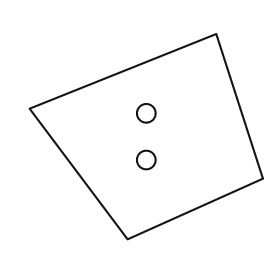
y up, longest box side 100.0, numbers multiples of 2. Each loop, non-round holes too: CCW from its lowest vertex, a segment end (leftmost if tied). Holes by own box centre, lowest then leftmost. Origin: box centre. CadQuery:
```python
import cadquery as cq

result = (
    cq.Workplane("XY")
    .moveTo(-8.0, -44.0)
    .lineTo(50.0, -18.0)
    .lineTo(30.0, 44.0)
    .lineTo(-50.0, 12.0)
    .close()
    .moveTo(0.0, -10.0)
    .circle(4.0)
    .moveTo(0.0, 10.0)
    .circle(4.0)
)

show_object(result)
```